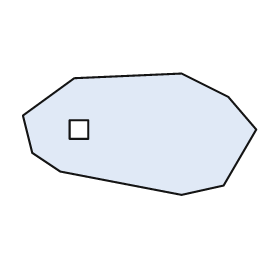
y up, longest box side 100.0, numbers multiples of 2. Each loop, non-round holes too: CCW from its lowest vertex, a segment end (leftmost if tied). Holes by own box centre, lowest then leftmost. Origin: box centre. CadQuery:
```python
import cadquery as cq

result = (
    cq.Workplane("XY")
    .moveTo(18.0, -26.0)
    .lineTo(36.0, -22.0)
    .lineTo(50.0, 2.0)
    .lineTo(38.0, 16.0)
    .lineTo(18.0, 26.0)
    .lineTo(-28.0, 24.0)
    .lineTo(-50.0, 8.0)
    .lineTo(-46.0, -8.0)
    .lineTo(-34.0, -16.0)
    .close()
    .moveTo(-30.0, -2.0)
    .lineTo(-22.0, -2.0)
    .lineTo(-22.0, 6.0)
    .lineTo(-30.0, 6.0)
    .close()
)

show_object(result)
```